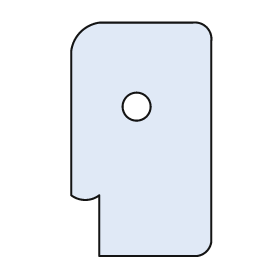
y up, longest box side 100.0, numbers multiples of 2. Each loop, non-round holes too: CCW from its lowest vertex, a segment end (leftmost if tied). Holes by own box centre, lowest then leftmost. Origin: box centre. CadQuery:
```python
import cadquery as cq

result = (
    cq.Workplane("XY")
    .moveTo(-18.0, -50.0)
    .lineTo(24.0, -50.0)
    .threePointArc((28.0, -48.0), (30.0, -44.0))
    .lineTo(30.0, 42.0)
    .threePointArc((28.0, 48.0), (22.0, 50.0))
    .lineTo(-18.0, 50.0)
    .threePointArc((-26.0, 46.0), (-30.0, 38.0))
    .lineTo(-30.0, -24.0)
    .threePointArc((-24.0, -26.0), (-18.0, -24.0))
    .close()
    .moveTo(-2.0, 14.0)
    .circle(6.0)
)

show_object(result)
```